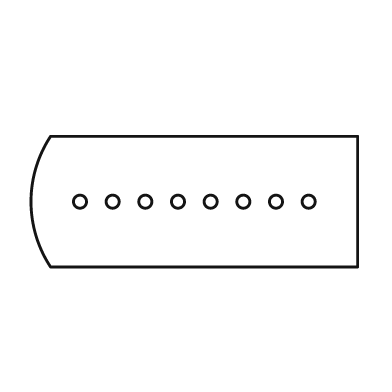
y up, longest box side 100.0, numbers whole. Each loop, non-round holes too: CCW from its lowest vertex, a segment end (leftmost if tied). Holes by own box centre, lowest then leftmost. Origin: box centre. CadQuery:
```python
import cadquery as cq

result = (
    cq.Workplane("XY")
    .moveTo(-44.0, -20.0)
    .lineTo(50.0, -20.0)
    .lineTo(50.0, 20.0)
    .lineTo(-44.0, 20.0)
    .threePointArc((-50.0, 0.0), (-44.0, -20.0))
    .close()
    .moveTo(-35.0, 0.0)
    .circle(2.0)
    .moveTo(-25.0, 0.0)
    .circle(2.0)
    .moveTo(-15.0, 0.0)
    .circle(2.0)
    .moveTo(-5.0, 0.0)
    .circle(2.0)
    .moveTo(5.0, 0.0)
    .circle(2.0)
    .moveTo(15.0, 0.0)
    .circle(2.0)
    .moveTo(25.0, 0.0)
    .circle(2.0)
    .moveTo(35.0, 0.0)
    .circle(2.0)
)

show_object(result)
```